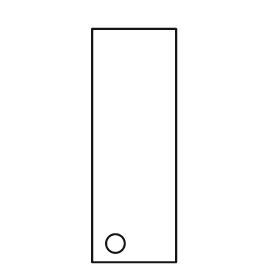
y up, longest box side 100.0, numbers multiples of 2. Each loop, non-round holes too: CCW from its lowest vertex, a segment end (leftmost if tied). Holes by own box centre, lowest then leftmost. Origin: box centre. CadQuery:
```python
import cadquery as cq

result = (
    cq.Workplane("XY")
    .moveTo(-18.0, -50.0)
    .lineTo(18.0, -50.0)
    .lineTo(18.0, 50.0)
    .lineTo(-18.0, 50.0)
    .close()
    .moveTo(-8.0, -42.0)
    .circle(4.0)
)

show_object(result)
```